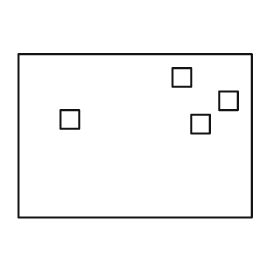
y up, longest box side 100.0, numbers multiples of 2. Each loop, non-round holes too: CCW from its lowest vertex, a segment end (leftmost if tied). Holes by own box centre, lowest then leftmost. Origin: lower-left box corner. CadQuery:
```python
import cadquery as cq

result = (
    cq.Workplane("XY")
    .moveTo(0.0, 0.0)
    .lineTo(100.0, 0.0)
    .lineTo(100.0, 70.0)
    .lineTo(0.0, 70.0)
    .close()
    .moveTo(74.0, 36.0)
    .lineTo(82.0, 36.0)
    .lineTo(82.0, 44.0)
    .lineTo(74.0, 44.0)
    .close()
    .moveTo(18.0, 38.0)
    .lineTo(26.0, 38.0)
    .lineTo(26.0, 46.0)
    .lineTo(18.0, 46.0)
    .close()
    .moveTo(86.0, 46.0)
    .lineTo(94.0, 46.0)
    .lineTo(94.0, 54.0)
    .lineTo(86.0, 54.0)
    .close()
    .moveTo(66.0, 56.0)
    .lineTo(74.0, 56.0)
    .lineTo(74.0, 64.0)
    .lineTo(66.0, 64.0)
    .close()
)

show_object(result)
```